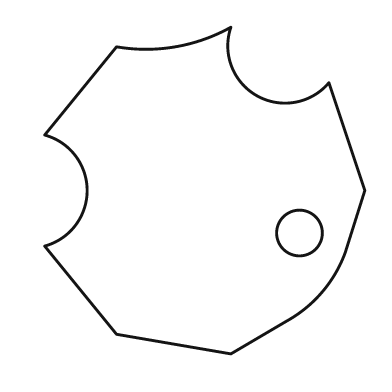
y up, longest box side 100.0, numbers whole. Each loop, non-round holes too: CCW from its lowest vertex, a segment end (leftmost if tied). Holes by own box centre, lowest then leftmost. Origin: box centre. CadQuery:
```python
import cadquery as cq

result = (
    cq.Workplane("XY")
    .moveTo(8.0, -50.0)
    .lineTo(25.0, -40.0)
    .threePointArc((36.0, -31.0), (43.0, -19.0))
    .lineTo(49.0, 0.0)
    .lineTo(38.0, 33.0)
    .threePointArc((16.0, 29.0), (8.0, 50.0))
    .threePointArc((-9.0, 44.0), (-27.0, 44.0))
    .lineTo(-49.0, 17.0)
    .threePointArc((-36.0, 0.0), (-49.0, -17.0))
    .lineTo(-27.0, -44.0)
    .close()
    .moveTo(29.0, -13.0)
    .circle(7.0)
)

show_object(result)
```